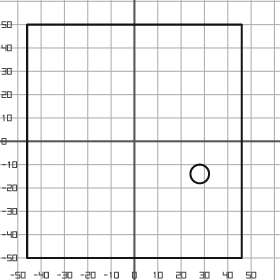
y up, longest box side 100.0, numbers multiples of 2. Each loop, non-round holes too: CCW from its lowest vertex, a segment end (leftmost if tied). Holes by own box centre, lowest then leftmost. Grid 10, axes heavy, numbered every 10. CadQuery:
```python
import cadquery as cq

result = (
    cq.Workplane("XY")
    .moveTo(-46.0, -50.0)
    .lineTo(46.0, -50.0)
    .lineTo(46.0, 50.0)
    .lineTo(-46.0, 50.0)
    .close()
    .moveTo(28.0, -14.0)
    .circle(4.0)
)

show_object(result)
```